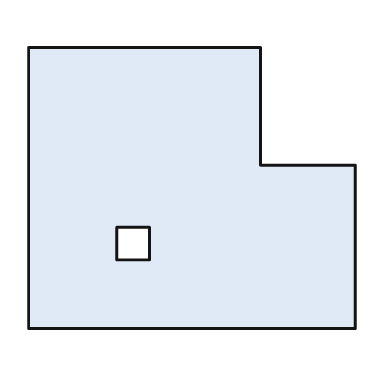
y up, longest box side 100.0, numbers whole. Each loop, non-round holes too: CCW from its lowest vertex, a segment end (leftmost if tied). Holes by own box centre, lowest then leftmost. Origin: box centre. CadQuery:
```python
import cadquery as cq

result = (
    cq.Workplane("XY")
    .moveTo(-50.0, -43.0)
    .lineTo(50.0, -43.0)
    .lineTo(50.0, 7.0)
    .lineTo(21.0, 7.0)
    .lineTo(21.0, 43.0)
    .lineTo(-50.0, 43.0)
    .close()
    .moveTo(-23.0, -22.0)
    .lineTo(-13.0, -22.0)
    .lineTo(-13.0, -12.0)
    .lineTo(-23.0, -12.0)
    .close()
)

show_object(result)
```